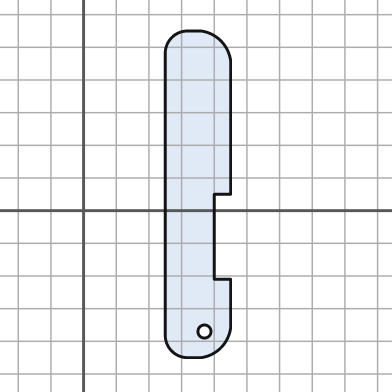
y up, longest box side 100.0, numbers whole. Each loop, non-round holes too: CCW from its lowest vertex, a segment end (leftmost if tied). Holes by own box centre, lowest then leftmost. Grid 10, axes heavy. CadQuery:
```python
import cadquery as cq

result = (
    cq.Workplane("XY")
    .moveTo(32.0, -45.0)
    .lineTo(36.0, -45.0)
    .threePointArc((42.0, -42.0), (45.0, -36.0))
    .lineTo(45.0, -21.0)
    .lineTo(40.0, -21.0)
    .lineTo(40.0, 5.0)
    .lineTo(45.0, 5.0)
    .lineTo(45.0, 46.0)
    .threePointArc((42.0, 52.0), (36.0, 55.0))
    .lineTo(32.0, 55.0)
    .threePointArc((27.0, 53.0), (25.0, 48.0))
    .lineTo(25.0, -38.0)
    .threePointArc((27.0, -43.0), (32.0, -45.0))
    .close()
    .moveTo(37.0, -37.0)
    .circle(2.0)
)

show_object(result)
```